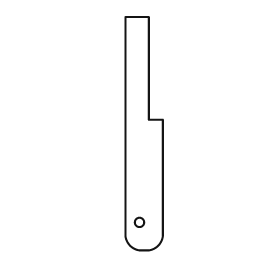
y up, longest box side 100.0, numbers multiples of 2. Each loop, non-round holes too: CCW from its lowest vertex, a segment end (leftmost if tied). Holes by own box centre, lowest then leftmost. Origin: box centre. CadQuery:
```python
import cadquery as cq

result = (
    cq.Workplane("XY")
    .moveTo(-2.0, -50.0)
    .lineTo(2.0, -50.0)
    .threePointArc((6.0, -48.0), (8.0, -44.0))
    .lineTo(8.0, 6.0)
    .lineTo(2.0, 6.0)
    .lineTo(2.0, 50.0)
    .lineTo(-8.0, 50.0)
    .lineTo(-8.0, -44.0)
    .threePointArc((-6.0, -48.0), (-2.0, -50.0))
    .close()
    .moveTo(-2.0, -38.0)
    .circle(2.0)
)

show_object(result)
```